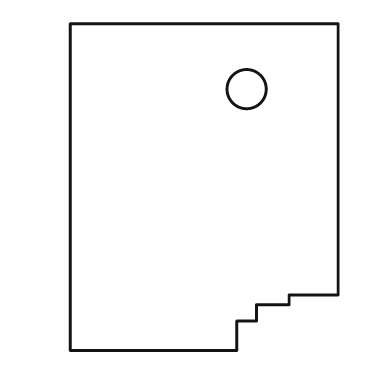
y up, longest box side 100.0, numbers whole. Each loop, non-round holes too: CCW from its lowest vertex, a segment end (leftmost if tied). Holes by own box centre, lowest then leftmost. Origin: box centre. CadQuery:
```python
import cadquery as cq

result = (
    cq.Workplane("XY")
    .moveTo(-41.0, -50.0)
    .lineTo(10.0, -50.0)
    .lineTo(10.0, -41.0)
    .lineTo(16.0, -41.0)
    .lineTo(16.0, -36.0)
    .lineTo(26.0, -36.0)
    .lineTo(26.0, -33.0)
    .lineTo(41.0, -33.0)
    .lineTo(41.0, 50.0)
    .lineTo(-41.0, 50.0)
    .close()
    .moveTo(13.0, 30.0)
    .circle(6.0)
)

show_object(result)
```